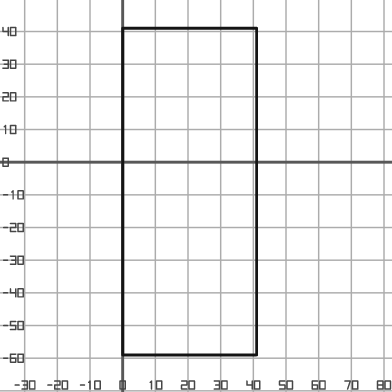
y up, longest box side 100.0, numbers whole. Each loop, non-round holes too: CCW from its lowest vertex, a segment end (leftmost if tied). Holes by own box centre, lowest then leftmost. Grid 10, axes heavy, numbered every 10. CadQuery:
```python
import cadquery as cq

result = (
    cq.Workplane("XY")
    .moveTo(0.0, -59.0)
    .lineTo(41.0, -59.0)
    .lineTo(41.0, 41.0)
    .lineTo(0.0, 41.0)
    .close()
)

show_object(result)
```